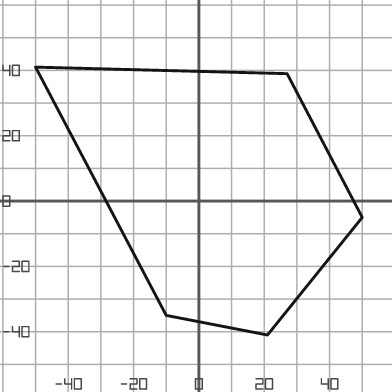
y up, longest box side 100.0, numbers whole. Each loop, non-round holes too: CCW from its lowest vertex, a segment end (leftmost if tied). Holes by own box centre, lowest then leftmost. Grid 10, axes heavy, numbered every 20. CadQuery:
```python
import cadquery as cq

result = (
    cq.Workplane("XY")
    .moveTo(21.0, -41.0)
    .lineTo(50.0, -5.0)
    .lineTo(27.0, 39.0)
    .lineTo(-50.0, 41.0)
    .lineTo(-10.0, -35.0)
    .close()
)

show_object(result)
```